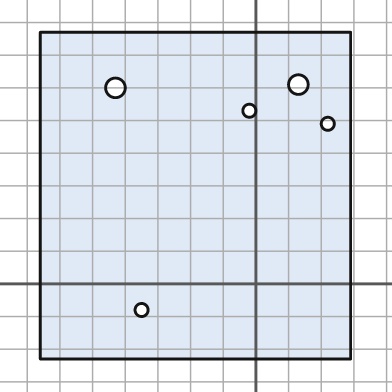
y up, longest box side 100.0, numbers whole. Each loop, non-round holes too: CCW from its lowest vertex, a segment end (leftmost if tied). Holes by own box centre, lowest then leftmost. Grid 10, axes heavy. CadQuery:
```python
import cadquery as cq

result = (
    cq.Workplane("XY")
    .moveTo(-66.0, -23.0)
    .lineTo(29.0, -23.0)
    .lineTo(29.0, 77.0)
    .lineTo(-66.0, 77.0)
    .close()
    .moveTo(-35.0, -8.0)
    .circle(2.0)
    .moveTo(22.0, 49.0)
    .circle(2.0)
    .moveTo(-2.0, 53.0)
    .circle(2.0)
    .moveTo(-43.0, 60.0)
    .circle(3.0)
    .moveTo(13.0, 61.0)
    .circle(3.0)
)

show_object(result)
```